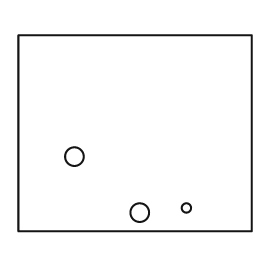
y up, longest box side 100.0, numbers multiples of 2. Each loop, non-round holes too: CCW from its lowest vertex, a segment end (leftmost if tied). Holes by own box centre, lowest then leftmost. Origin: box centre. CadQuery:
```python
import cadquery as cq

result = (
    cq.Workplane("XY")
    .moveTo(-50.0, -42.0)
    .lineTo(50.0, -42.0)
    .lineTo(50.0, 42.0)
    .lineTo(-50.0, 42.0)
    .close()
    .moveTo(2.0, -34.0)
    .circle(4.0)
    .moveTo(22.0, -32.0)
    .circle(2.0)
    .moveTo(-26.0, -10.0)
    .circle(4.0)
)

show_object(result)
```